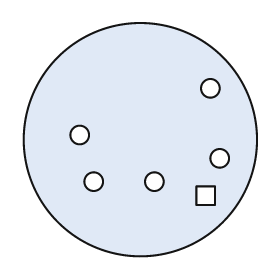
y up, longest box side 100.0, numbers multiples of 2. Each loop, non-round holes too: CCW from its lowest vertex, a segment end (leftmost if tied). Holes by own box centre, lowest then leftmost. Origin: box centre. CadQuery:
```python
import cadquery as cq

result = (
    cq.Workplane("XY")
    .moveTo(0.0, 0.0)
    .circle(50.0)
    .moveTo(24.0, -28.0)
    .lineTo(32.0, -28.0)
    .lineTo(32.0, -20.0)
    .lineTo(24.0, -20.0)
    .close()
    .moveTo(-20.0, -18.0)
    .circle(4.0)
    .moveTo(6.0, -18.0)
    .circle(4.0)
    .moveTo(34.0, -8.0)
    .circle(4.0)
    .moveTo(-26.0, 2.0)
    .circle(4.0)
    .moveTo(30.0, 22.0)
    .circle(4.0)
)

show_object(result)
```